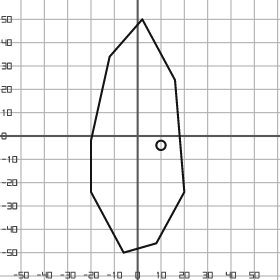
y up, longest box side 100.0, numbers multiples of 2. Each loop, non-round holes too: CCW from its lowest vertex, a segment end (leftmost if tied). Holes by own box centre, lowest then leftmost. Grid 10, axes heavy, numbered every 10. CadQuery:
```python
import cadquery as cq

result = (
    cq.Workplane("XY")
    .moveTo(-6.0, -50.0)
    .lineTo(8.0, -46.0)
    .lineTo(20.0, -24.0)
    .lineTo(16.0, 24.0)
    .lineTo(2.0, 50.0)
    .lineTo(-12.0, 34.0)
    .lineTo(-20.0, -2.0)
    .lineTo(-20.0, -24.0)
    .close()
    .moveTo(10.0, -4.0)
    .circle(2.0)
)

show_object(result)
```